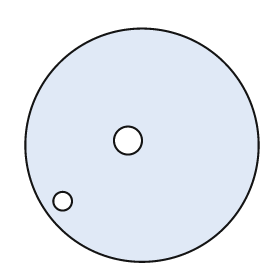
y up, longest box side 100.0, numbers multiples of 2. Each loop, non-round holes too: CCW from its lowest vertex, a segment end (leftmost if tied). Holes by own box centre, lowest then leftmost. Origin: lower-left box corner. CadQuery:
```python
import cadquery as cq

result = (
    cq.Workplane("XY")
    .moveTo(50.0, 50.0)
    .circle(50.0)
    .moveTo(16.0, 26.0)
    .circle(4.0)
    .moveTo(44.0, 52.0)
    .circle(6.0)
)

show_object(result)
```